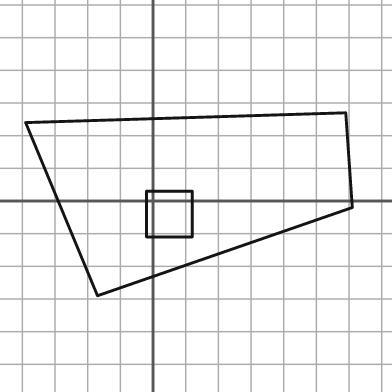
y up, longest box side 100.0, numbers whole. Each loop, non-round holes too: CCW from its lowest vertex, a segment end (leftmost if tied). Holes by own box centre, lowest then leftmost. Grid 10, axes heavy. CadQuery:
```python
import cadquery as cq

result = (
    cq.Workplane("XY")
    .moveTo(-17.0, -29.0)
    .lineTo(61.0, -2.0)
    .lineTo(59.0, 27.0)
    .lineTo(-39.0, 24.0)
    .close()
    .moveTo(-2.0, -11.0)
    .lineTo(12.0, -11.0)
    .lineTo(12.0, 3.0)
    .lineTo(-2.0, 3.0)
    .close()
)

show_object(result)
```